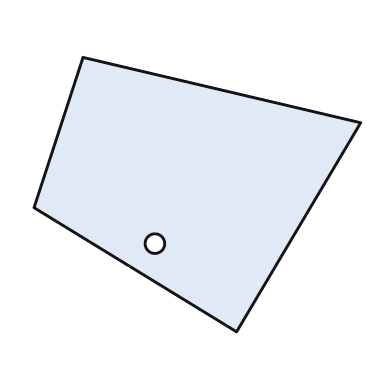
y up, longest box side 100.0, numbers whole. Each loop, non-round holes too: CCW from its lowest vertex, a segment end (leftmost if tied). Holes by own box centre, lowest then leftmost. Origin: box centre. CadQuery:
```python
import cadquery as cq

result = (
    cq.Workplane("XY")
    .moveTo(12.0, -42.0)
    .lineTo(50.0, 22.0)
    .lineTo(-35.0, 42.0)
    .lineTo(-50.0, -4.0)
    .close()
    .moveTo(-13.0, -15.0)
    .circle(3.0)
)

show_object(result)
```